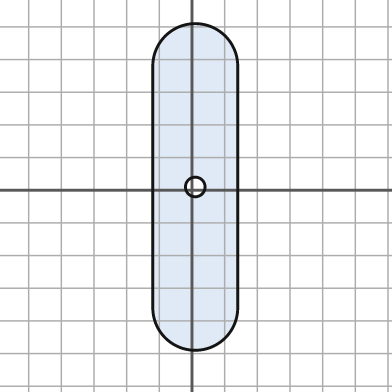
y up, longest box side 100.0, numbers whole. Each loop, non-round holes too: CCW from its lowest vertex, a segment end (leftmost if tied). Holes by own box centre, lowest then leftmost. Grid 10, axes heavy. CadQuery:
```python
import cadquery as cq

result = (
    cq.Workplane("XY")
    .moveTo(-12.0, -36.0)
    .threePointArc((1.0, -49.0), (14.0, -36.0))
    .lineTo(14.0, 38.0)
    .threePointArc((1.0, 51.0), (-12.0, 38.0))
    .close()
    .moveTo(1.0, 1.0)
    .circle(3.0)
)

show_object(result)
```